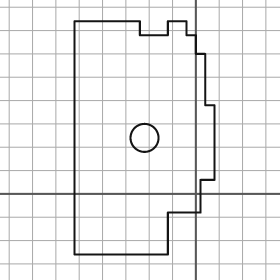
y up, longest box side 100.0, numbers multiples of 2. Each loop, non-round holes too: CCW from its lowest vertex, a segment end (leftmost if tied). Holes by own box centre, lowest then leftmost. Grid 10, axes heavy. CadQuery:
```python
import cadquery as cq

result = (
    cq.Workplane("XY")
    .moveTo(-52.0, -26.0)
    .lineTo(-12.0, -26.0)
    .lineTo(-12.0, -8.0)
    .lineTo(2.0, -8.0)
    .lineTo(2.0, 6.0)
    .lineTo(8.0, 6.0)
    .lineTo(8.0, 38.0)
    .lineTo(4.0, 38.0)
    .lineTo(4.0, 60.0)
    .lineTo(0.0, 60.0)
    .lineTo(0.0, 68.0)
    .lineTo(-4.0, 68.0)
    .lineTo(-4.0, 74.0)
    .lineTo(-12.0, 74.0)
    .lineTo(-12.0, 68.0)
    .lineTo(-24.0, 68.0)
    .lineTo(-24.0, 74.0)
    .lineTo(-52.0, 74.0)
    .close()
    .moveTo(-22.0, 24.0)
    .circle(6.0)
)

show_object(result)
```